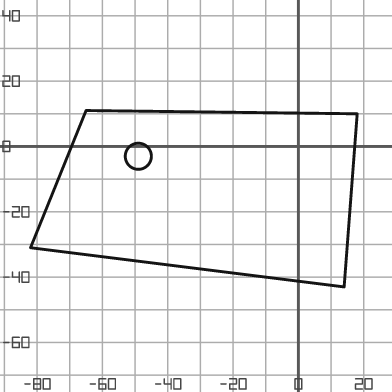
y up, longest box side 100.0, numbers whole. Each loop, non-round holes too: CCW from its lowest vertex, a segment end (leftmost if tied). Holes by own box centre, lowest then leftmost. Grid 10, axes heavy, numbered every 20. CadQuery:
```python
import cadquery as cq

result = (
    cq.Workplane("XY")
    .moveTo(14.0, -43.0)
    .lineTo(18.0, 10.0)
    .lineTo(-65.0, 11.0)
    .lineTo(-82.0, -31.0)
    .close()
    .moveTo(-49.0, -3.0)
    .circle(4.0)
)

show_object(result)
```